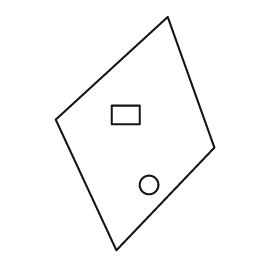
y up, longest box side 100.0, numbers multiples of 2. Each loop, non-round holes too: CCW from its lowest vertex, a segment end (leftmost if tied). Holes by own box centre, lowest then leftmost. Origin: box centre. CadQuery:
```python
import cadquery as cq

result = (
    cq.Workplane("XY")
    .moveTo(-8.0, -50.0)
    .lineTo(34.0, -6.0)
    .lineTo(14.0, 50.0)
    .lineTo(-34.0, 6.0)
    .close()
    .moveTo(6.0, -22.0)
    .circle(4.0)
    .moveTo(-10.0, 4.0)
    .lineTo(2.0, 4.0)
    .lineTo(2.0, 12.0)
    .lineTo(-10.0, 12.0)
    .close()
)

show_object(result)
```